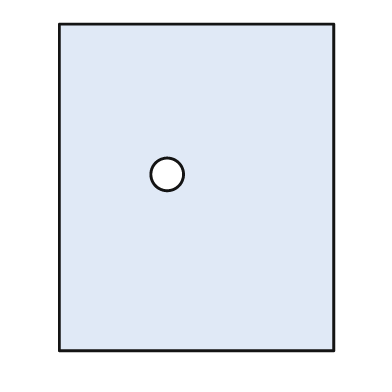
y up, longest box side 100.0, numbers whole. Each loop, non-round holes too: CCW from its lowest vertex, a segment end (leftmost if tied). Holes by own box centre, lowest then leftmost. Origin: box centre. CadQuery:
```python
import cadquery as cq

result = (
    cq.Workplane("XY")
    .moveTo(-42.0, -50.0)
    .lineTo(42.0, -50.0)
    .lineTo(42.0, 50.0)
    .lineTo(-42.0, 50.0)
    .close()
    .moveTo(-9.0, 4.0)
    .circle(5.0)
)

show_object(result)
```